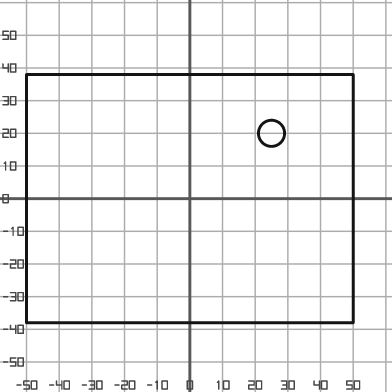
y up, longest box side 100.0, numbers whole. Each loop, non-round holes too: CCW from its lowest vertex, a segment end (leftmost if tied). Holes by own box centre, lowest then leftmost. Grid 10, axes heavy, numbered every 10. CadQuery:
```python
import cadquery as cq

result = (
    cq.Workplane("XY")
    .moveTo(-50.0, -38.0)
    .lineTo(50.0, -38.0)
    .lineTo(50.0, 38.0)
    .lineTo(-50.0, 38.0)
    .close()
    .moveTo(25.0, 20.0)
    .circle(4.0)
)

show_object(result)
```